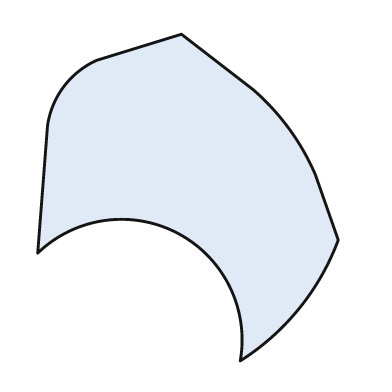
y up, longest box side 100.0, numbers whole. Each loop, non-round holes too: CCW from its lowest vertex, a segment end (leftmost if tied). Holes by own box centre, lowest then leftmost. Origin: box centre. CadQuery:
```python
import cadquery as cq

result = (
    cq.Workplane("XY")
    .moveTo(16.0, -50.0)
    .threePointArc((34.0, -34.0), (46.0, -13.0))
    .lineTo(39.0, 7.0)
    .threePointArc((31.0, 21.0), (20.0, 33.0))
    .lineTo(-2.0, 50.0)
    .lineTo(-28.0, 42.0)
    .threePointArc((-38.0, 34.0), (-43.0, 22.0))
    .lineTo(-46.0, -17.0)
    .threePointArc((-3.0, -11.0), (16.0, -50.0))
    .close()
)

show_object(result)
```